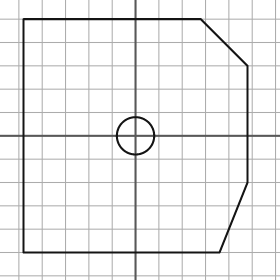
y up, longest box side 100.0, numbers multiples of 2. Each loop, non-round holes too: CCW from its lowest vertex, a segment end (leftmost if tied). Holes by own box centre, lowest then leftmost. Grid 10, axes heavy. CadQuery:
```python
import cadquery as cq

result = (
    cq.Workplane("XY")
    .moveTo(-48.0, -50.0)
    .lineTo(36.0, -50.0)
    .lineTo(48.0, -20.0)
    .lineTo(48.0, 30.0)
    .lineTo(28.0, 50.0)
    .lineTo(-48.0, 50.0)
    .close()
    .moveTo(0.0, 0.0)
    .circle(8.0)
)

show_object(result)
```